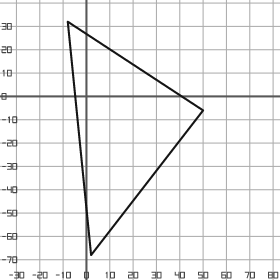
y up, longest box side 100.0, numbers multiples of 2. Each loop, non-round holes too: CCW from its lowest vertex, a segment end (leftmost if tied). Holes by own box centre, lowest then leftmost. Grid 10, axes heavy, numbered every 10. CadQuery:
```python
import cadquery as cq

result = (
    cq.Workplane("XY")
    .moveTo(2.0, -68.0)
    .lineTo(50.0, -6.0)
    .lineTo(-8.0, 32.0)
    .close()
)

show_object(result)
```